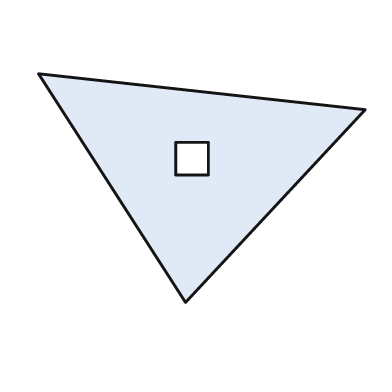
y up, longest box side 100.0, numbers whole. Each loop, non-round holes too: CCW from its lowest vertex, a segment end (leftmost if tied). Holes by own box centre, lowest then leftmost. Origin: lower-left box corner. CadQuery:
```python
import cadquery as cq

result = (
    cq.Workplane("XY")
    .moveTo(45.0, 0.0)
    .lineTo(100.0, 59.0)
    .lineTo(0.0, 70.0)
    .close()
    .moveTo(42.0, 39.0)
    .lineTo(52.0, 39.0)
    .lineTo(52.0, 49.0)
    .lineTo(42.0, 49.0)
    .close()
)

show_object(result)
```